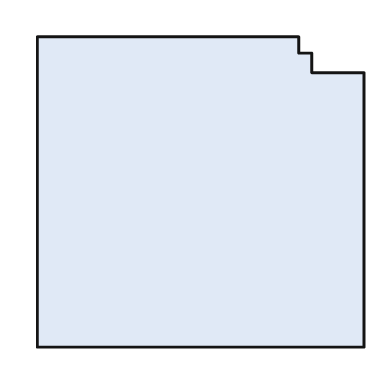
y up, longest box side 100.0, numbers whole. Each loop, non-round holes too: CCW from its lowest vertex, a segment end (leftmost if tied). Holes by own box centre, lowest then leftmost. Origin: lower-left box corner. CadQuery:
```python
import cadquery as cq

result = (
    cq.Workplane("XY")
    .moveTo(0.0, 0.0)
    .lineTo(100.0, 0.0)
    .lineTo(100.0, 84.0)
    .lineTo(84.0, 84.0)
    .lineTo(84.0, 90.0)
    .lineTo(80.0, 90.0)
    .lineTo(80.0, 95.0)
    .lineTo(0.0, 95.0)
    .close()
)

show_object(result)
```